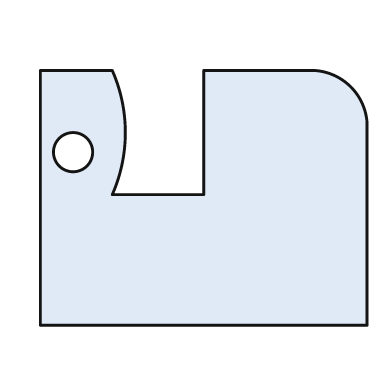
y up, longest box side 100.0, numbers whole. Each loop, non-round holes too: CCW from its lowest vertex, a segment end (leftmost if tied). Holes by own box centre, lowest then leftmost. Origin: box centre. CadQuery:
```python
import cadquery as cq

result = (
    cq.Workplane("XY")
    .moveTo(-50.0, -39.0)
    .lineTo(50.0, -39.0)
    .lineTo(50.0, 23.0)
    .threePointArc((45.0, 34.0), (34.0, 39.0))
    .lineTo(0.0, 39.0)
    .lineTo(0.0, 1.0)
    .lineTo(-28.0, 1.0)
    .threePointArc((-24.0, 20.0), (-28.0, 39.0))
    .lineTo(-50.0, 39.0)
    .close()
    .moveTo(-40.0, 14.0)
    .circle(6.0)
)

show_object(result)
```